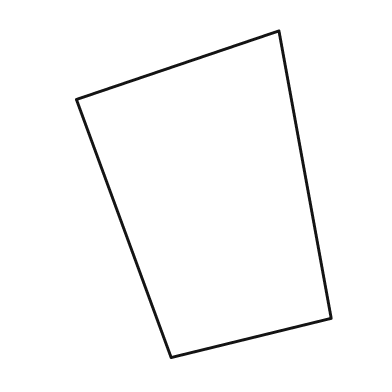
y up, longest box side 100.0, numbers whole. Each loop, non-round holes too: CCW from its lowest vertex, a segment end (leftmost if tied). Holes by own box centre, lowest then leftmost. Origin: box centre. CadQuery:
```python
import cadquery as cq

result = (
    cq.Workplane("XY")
    .moveTo(-10.0, -50.0)
    .lineTo(39.0, -38.0)
    .lineTo(23.0, 50.0)
    .lineTo(-39.0, 29.0)
    .close()
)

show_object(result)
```